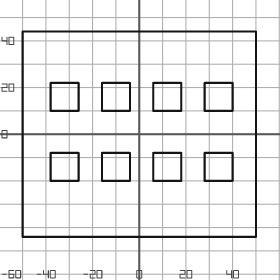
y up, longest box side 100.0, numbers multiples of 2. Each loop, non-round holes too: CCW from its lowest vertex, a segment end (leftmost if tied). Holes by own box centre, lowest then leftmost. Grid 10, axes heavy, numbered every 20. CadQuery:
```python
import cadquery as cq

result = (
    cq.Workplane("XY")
    .moveTo(-50.0, -44.0)
    .lineTo(50.0, -44.0)
    .lineTo(50.0, 44.0)
    .lineTo(-50.0, 44.0)
    .close()
    .moveTo(-38.0, -20.0)
    .lineTo(-26.0, -20.0)
    .lineTo(-26.0, -8.0)
    .lineTo(-38.0, -8.0)
    .close()
    .moveTo(-16.0, -20.0)
    .lineTo(-4.0, -20.0)
    .lineTo(-4.0, -8.0)
    .lineTo(-16.0, -8.0)
    .close()
    .moveTo(6.0, -20.0)
    .lineTo(18.0, -20.0)
    .lineTo(18.0, -8.0)
    .lineTo(6.0, -8.0)
    .close()
    .moveTo(28.0, -20.0)
    .lineTo(40.0, -20.0)
    .lineTo(40.0, -8.0)
    .lineTo(28.0, -8.0)
    .close()
    .moveTo(-38.0, 10.0)
    .lineTo(-26.0, 10.0)
    .lineTo(-26.0, 22.0)
    .lineTo(-38.0, 22.0)
    .close()
    .moveTo(-16.0, 10.0)
    .lineTo(-4.0, 10.0)
    .lineTo(-4.0, 22.0)
    .lineTo(-16.0, 22.0)
    .close()
    .moveTo(6.0, 10.0)
    .lineTo(18.0, 10.0)
    .lineTo(18.0, 22.0)
    .lineTo(6.0, 22.0)
    .close()
    .moveTo(28.0, 10.0)
    .lineTo(40.0, 10.0)
    .lineTo(40.0, 22.0)
    .lineTo(28.0, 22.0)
    .close()
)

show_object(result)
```